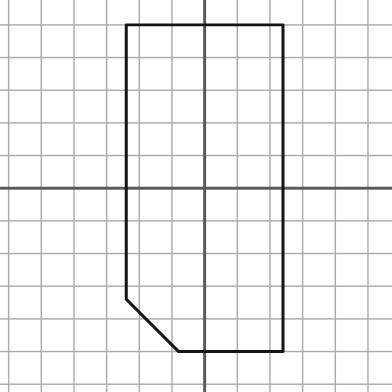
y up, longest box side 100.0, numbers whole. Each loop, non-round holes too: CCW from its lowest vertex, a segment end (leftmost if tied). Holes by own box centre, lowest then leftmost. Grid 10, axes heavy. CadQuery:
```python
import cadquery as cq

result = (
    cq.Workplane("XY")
    .moveTo(-8.0, -50.0)
    .lineTo(24.0, -50.0)
    .lineTo(24.0, 50.0)
    .lineTo(-24.0, 50.0)
    .lineTo(-24.0, -34.0)
    .close()
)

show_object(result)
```